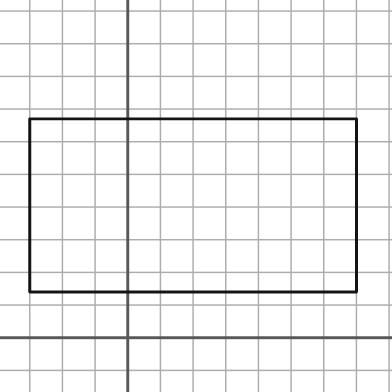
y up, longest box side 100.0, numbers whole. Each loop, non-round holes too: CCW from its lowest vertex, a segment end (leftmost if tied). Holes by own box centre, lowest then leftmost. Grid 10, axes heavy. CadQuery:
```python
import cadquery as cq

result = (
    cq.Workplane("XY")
    .moveTo(-30.0, 14.0)
    .lineTo(70.0, 14.0)
    .lineTo(70.0, 67.0)
    .lineTo(-30.0, 67.0)
    .close()
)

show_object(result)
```